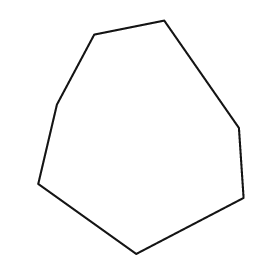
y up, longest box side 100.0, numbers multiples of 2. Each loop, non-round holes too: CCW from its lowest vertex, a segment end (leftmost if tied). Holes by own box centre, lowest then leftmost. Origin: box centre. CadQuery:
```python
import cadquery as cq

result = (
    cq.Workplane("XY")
    .moveTo(-2.0, -50.0)
    .lineTo(44.0, -26.0)
    .lineTo(42.0, 4.0)
    .lineTo(10.0, 50.0)
    .lineTo(-20.0, 44.0)
    .lineTo(-36.0, 14.0)
    .lineTo(-44.0, -20.0)
    .close()
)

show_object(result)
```